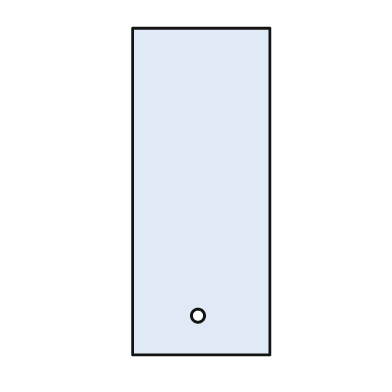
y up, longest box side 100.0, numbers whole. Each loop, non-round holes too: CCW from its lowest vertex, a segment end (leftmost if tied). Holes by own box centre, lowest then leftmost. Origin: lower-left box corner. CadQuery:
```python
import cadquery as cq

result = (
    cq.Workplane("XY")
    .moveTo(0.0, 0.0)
    .lineTo(42.0, 0.0)
    .lineTo(42.0, 100.0)
    .lineTo(0.0, 100.0)
    .close()
    .moveTo(20.0, 12.0)
    .circle(2.0)
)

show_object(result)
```